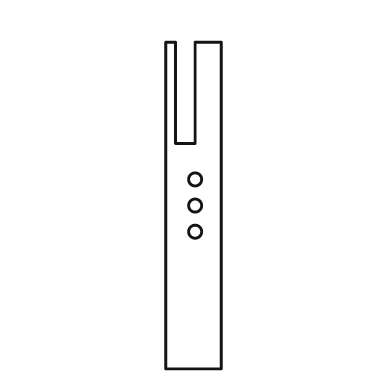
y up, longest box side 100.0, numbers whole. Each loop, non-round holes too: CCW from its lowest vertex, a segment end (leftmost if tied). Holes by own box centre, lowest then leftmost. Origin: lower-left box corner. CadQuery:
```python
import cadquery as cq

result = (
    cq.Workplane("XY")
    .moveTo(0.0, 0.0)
    .lineTo(17.0, 0.0)
    .lineTo(17.0, 100.0)
    .lineTo(9.0, 100.0)
    .lineTo(9.0, 69.0)
    .lineTo(3.0, 69.0)
    .lineTo(3.0, 100.0)
    .lineTo(0.0, 100.0)
    .close()
    .moveTo(9.0, 42.0)
    .circle(2.0)
    .moveTo(9.0, 50.0)
    .circle(2.0)
    .moveTo(9.0, 58.0)
    .circle(2.0)
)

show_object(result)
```